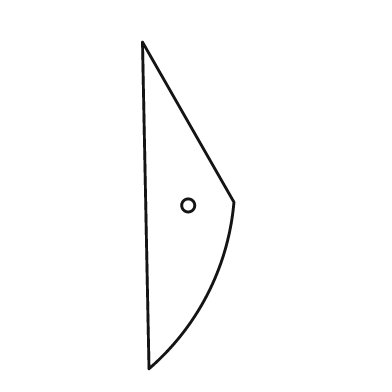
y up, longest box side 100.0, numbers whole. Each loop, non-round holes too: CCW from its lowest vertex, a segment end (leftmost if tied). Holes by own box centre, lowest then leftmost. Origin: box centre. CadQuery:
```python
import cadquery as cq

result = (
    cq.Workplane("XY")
    .moveTo(-12.0, -50.0)
    .threePointArc((6.0, -27.0), (14.0, 1.0))
    .lineTo(-14.0, 50.0)
    .close()
    .moveTo(0.0, 0.0)
    .circle(2.0)
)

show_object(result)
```